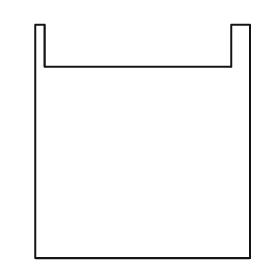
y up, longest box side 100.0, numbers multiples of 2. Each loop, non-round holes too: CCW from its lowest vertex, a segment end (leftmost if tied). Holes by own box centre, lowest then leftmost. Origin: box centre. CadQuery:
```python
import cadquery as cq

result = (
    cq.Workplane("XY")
    .moveTo(-46.0, -50.0)
    .lineTo(46.0, -50.0)
    .lineTo(46.0, 50.0)
    .lineTo(38.0, 50.0)
    .lineTo(38.0, 32.0)
    .lineTo(-42.0, 32.0)
    .lineTo(-42.0, 50.0)
    .lineTo(-46.0, 50.0)
    .close()
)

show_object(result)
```